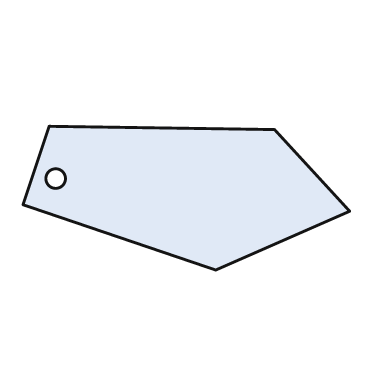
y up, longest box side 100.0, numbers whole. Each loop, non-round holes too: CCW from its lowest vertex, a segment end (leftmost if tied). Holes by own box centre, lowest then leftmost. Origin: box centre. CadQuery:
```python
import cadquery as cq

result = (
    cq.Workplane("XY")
    .moveTo(9.0, -22.0)
    .lineTo(50.0, -4.0)
    .lineTo(27.0, 21.0)
    .lineTo(-42.0, 22.0)
    .lineTo(-50.0, -2.0)
    .close()
    .moveTo(-40.0, 6.0)
    .circle(3.0)
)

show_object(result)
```